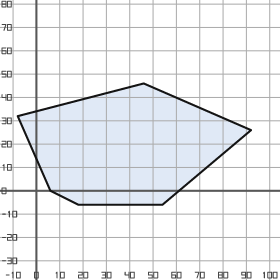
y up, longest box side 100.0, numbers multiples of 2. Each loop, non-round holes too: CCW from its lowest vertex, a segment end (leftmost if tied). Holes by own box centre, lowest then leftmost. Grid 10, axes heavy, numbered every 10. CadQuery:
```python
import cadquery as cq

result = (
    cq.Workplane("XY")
    .moveTo(18.0, -6.0)
    .lineTo(54.0, -6.0)
    .lineTo(92.0, 26.0)
    .lineTo(46.0, 46.0)
    .lineTo(-8.0, 32.0)
    .lineTo(6.0, 0.0)
    .close()
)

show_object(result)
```